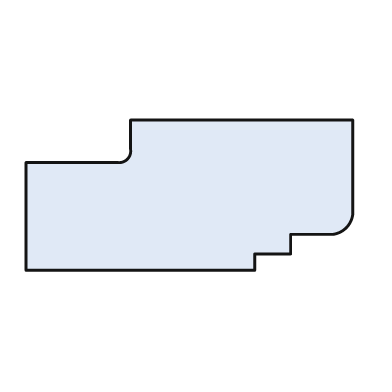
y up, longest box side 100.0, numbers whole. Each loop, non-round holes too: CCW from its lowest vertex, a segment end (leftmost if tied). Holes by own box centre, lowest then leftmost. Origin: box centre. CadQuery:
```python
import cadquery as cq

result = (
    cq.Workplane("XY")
    .moveTo(-50.0, -23.0)
    .lineTo(20.0, -23.0)
    .lineTo(20.0, -18.0)
    .lineTo(31.0, -18.0)
    .lineTo(31.0, -12.0)
    .lineTo(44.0, -12.0)
    .threePointArc((48.0, -10.0), (50.0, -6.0))
    .lineTo(50.0, 23.0)
    .lineTo(-18.0, 23.0)
    .lineTo(-18.0, 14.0)
    .threePointArc((-19.0, 11.0), (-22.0, 10.0))
    .lineTo(-50.0, 10.0)
    .close()
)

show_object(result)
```